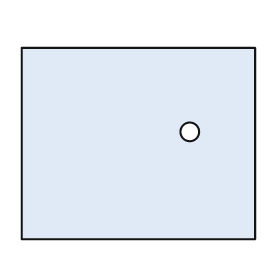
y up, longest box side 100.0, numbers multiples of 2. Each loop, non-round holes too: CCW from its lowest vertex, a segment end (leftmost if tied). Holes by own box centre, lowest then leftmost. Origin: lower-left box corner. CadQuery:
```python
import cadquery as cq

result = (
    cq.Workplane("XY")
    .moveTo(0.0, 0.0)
    .lineTo(100.0, 0.0)
    .lineTo(100.0, 82.0)
    .lineTo(0.0, 82.0)
    .close()
    .moveTo(72.0, 46.0)
    .circle(4.0)
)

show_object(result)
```